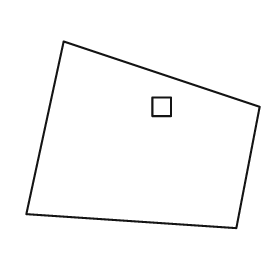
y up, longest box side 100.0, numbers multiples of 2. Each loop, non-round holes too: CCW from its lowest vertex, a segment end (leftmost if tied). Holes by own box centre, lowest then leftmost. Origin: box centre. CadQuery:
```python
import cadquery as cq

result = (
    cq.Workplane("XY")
    .moveTo(40.0, -40.0)
    .lineTo(50.0, 12.0)
    .lineTo(-34.0, 40.0)
    .lineTo(-50.0, -34.0)
    .close()
    .moveTo(4.0, 8.0)
    .lineTo(12.0, 8.0)
    .lineTo(12.0, 16.0)
    .lineTo(4.0, 16.0)
    .close()
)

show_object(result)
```